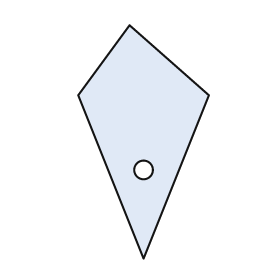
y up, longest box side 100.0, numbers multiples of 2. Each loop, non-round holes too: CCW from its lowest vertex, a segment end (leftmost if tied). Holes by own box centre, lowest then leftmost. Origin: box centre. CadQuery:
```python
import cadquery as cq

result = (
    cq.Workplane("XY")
    .moveTo(0.0, -50.0)
    .lineTo(28.0, 20.0)
    .lineTo(-6.0, 50.0)
    .lineTo(-28.0, 20.0)
    .close()
    .moveTo(0.0, -12.0)
    .circle(4.0)
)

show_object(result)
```